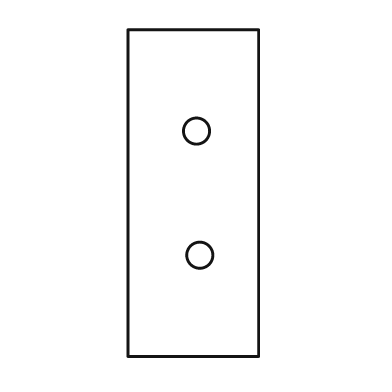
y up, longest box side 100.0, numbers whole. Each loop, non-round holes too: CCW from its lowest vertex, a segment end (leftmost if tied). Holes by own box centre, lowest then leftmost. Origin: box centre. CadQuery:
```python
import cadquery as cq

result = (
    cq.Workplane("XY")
    .moveTo(-20.0, -50.0)
    .lineTo(20.0, -50.0)
    .lineTo(20.0, 50.0)
    .lineTo(-20.0, 50.0)
    .close()
    .moveTo(2.0, -19.0)
    .circle(4.0)
    .moveTo(1.0, 19.0)
    .circle(4.0)
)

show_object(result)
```